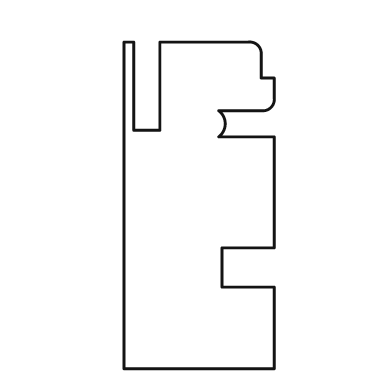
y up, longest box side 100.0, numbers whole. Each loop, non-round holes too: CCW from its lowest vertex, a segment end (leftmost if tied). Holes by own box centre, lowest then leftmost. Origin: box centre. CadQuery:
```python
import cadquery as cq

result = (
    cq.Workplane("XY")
    .moveTo(-23.0, -50.0)
    .lineTo(23.0, -50.0)
    .lineTo(23.0, -25.0)
    .lineTo(7.0, -25.0)
    .lineTo(7.0, -13.0)
    .lineTo(23.0, -13.0)
    .lineTo(23.0, 21.0)
    .lineTo(6.0, 21.0)
    .threePointArc((8.0, 25.0), (6.0, 29.0))
    .lineTo(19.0, 29.0)
    .threePointArc((22.0, 30.0), (23.0, 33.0))
    .lineTo(23.0, 39.0)
    .lineTo(19.0, 39.0)
    .lineTo(19.0, 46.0)
    .threePointArc((18.0, 49.0), (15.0, 50.0))
    .lineTo(-12.0, 50.0)
    .lineTo(-12.0, 23.0)
    .lineTo(-20.0, 23.0)
    .lineTo(-20.0, 50.0)
    .lineTo(-23.0, 50.0)
    .close()
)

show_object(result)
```